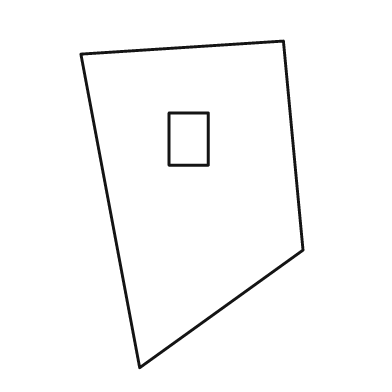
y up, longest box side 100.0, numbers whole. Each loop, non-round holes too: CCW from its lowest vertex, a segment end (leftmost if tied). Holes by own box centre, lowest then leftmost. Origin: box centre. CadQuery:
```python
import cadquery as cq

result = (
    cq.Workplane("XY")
    .moveTo(-16.0, -50.0)
    .lineTo(34.0, -14.0)
    .lineTo(28.0, 50.0)
    .lineTo(-34.0, 46.0)
    .close()
    .moveTo(-7.0, 12.0)
    .lineTo(5.0, 12.0)
    .lineTo(5.0, 28.0)
    .lineTo(-7.0, 28.0)
    .close()
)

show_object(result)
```